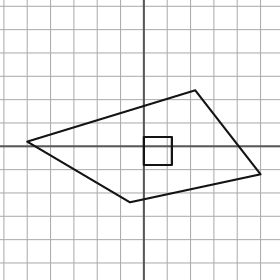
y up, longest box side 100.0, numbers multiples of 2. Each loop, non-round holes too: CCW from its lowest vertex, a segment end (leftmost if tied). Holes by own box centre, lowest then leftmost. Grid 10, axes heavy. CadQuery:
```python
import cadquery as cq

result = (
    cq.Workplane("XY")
    .moveTo(-6.0, -24.0)
    .lineTo(50.0, -12.0)
    .lineTo(22.0, 24.0)
    .lineTo(-50.0, 2.0)
    .close()
    .moveTo(0.0, -8.0)
    .lineTo(12.0, -8.0)
    .lineTo(12.0, 4.0)
    .lineTo(0.0, 4.0)
    .close()
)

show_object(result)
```